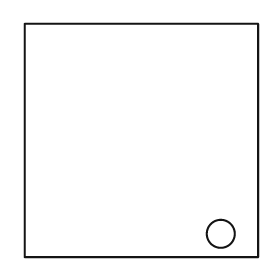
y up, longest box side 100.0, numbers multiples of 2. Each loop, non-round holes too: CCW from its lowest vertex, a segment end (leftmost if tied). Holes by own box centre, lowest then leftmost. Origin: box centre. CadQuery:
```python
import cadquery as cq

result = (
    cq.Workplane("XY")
    .moveTo(-50.0, -50.0)
    .lineTo(50.0, -50.0)
    .lineTo(50.0, 50.0)
    .lineTo(-50.0, 50.0)
    .close()
    .moveTo(34.0, -40.0)
    .circle(6.0)
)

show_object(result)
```